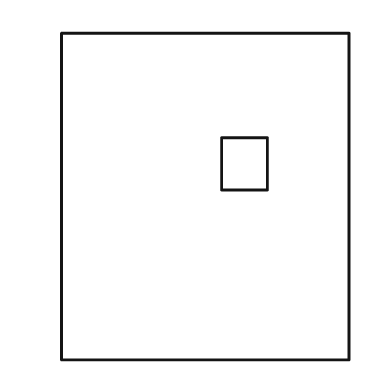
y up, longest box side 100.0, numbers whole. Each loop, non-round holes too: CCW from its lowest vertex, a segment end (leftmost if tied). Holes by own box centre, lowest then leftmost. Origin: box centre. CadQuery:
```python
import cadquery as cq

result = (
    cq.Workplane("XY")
    .moveTo(-44.0, -50.0)
    .lineTo(44.0, -50.0)
    .lineTo(44.0, 50.0)
    .lineTo(-44.0, 50.0)
    .close()
    .moveTo(5.0, 2.0)
    .lineTo(19.0, 2.0)
    .lineTo(19.0, 18.0)
    .lineTo(5.0, 18.0)
    .close()
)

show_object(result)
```